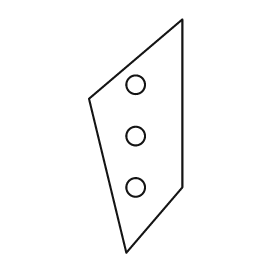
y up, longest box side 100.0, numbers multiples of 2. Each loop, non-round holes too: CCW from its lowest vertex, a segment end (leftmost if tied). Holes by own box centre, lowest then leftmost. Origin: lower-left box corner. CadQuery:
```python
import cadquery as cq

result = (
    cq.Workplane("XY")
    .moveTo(16.0, 0.0)
    .lineTo(40.0, 28.0)
    .lineTo(40.0, 100.0)
    .lineTo(0.0, 66.0)
    .close()
    .moveTo(20.0, 28.0)
    .circle(4.0)
    .moveTo(20.0, 50.0)
    .circle(4.0)
    .moveTo(20.0, 72.0)
    .circle(4.0)
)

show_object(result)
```